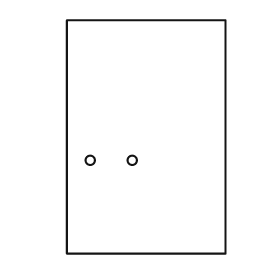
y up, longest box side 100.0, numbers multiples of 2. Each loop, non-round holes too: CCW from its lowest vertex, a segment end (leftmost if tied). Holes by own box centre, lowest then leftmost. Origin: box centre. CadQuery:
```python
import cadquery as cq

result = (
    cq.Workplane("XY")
    .moveTo(-34.0, -50.0)
    .lineTo(34.0, -50.0)
    .lineTo(34.0, 50.0)
    .lineTo(-34.0, 50.0)
    .close()
    .moveTo(-24.0, -10.0)
    .circle(2.0)
    .moveTo(-6.0, -10.0)
    .circle(2.0)
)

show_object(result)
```